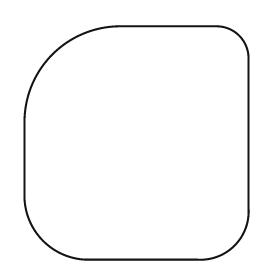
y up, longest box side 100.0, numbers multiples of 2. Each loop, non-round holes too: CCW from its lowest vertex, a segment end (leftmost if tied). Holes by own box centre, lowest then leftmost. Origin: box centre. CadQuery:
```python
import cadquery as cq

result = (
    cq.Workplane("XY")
    .moveTo(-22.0, -50.0)
    .lineTo(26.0, -50.0)
    .threePointArc((42.0, -44.0), (48.0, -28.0))
    .lineTo(48.0, 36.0)
    .threePointArc((44.0, 46.0), (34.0, 50.0))
    .lineTo(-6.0, 50.0)
    .threePointArc((-36.0, 38.0), (-48.0, 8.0))
    .lineTo(-48.0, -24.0)
    .threePointArc((-40.0, -42.0), (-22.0, -50.0))
    .close()
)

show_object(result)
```